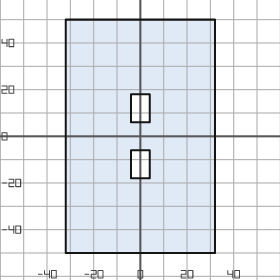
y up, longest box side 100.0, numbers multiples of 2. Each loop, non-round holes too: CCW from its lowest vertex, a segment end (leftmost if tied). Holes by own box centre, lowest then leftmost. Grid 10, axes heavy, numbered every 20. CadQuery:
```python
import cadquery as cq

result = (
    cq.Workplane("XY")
    .moveTo(-32.0, -50.0)
    .lineTo(32.0, -50.0)
    .lineTo(32.0, 50.0)
    .lineTo(-32.0, 50.0)
    .close()
    .moveTo(-4.0, -18.0)
    .lineTo(4.0, -18.0)
    .lineTo(4.0, -6.0)
    .lineTo(-4.0, -6.0)
    .close()
    .moveTo(-4.0, 6.0)
    .lineTo(4.0, 6.0)
    .lineTo(4.0, 18.0)
    .lineTo(-4.0, 18.0)
    .close()
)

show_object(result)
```